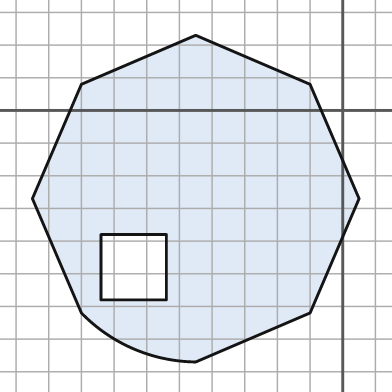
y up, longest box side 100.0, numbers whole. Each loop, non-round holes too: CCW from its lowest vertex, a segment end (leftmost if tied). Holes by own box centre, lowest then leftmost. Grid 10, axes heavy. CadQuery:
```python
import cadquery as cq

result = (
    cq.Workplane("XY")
    .moveTo(-45.0, -77.0)
    .lineTo(-10.0, -62.0)
    .lineTo(5.0, -27.0)
    .lineTo(-10.0, 8.0)
    .lineTo(-45.0, 23.0)
    .lineTo(-80.0, 8.0)
    .lineTo(-95.0, -27.0)
    .lineTo(-80.0, -62.0)
    .threePointArc((-64.0, -73.0), (-45.0, -77.0))
    .close()
    .moveTo(-74.0, -58.0)
    .lineTo(-54.0, -58.0)
    .lineTo(-54.0, -38.0)
    .lineTo(-74.0, -38.0)
    .close()
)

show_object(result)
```